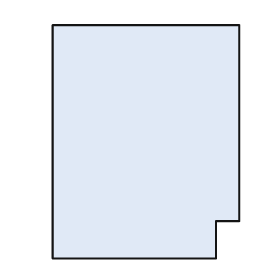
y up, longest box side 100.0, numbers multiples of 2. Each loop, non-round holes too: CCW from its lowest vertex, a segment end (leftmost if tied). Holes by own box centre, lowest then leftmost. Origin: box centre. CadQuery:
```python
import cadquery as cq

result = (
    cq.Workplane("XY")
    .moveTo(-40.0, -50.0)
    .lineTo(30.0, -50.0)
    .lineTo(30.0, -34.0)
    .lineTo(40.0, -34.0)
    .lineTo(40.0, 50.0)
    .lineTo(-40.0, 50.0)
    .close()
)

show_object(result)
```